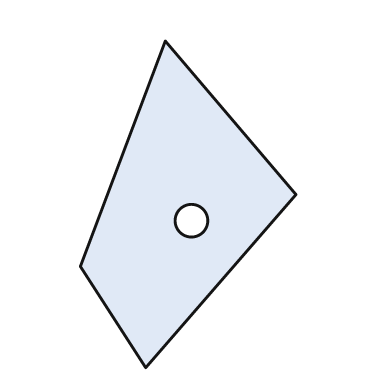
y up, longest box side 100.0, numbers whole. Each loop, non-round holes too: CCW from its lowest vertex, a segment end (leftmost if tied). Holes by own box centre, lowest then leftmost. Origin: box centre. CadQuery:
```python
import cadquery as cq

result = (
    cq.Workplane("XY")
    .moveTo(-13.0, -50.0)
    .lineTo(33.0, 3.0)
    .lineTo(-7.0, 50.0)
    .lineTo(-33.0, -19.0)
    .close()
    .moveTo(1.0, -5.0)
    .circle(5.0)
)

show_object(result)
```